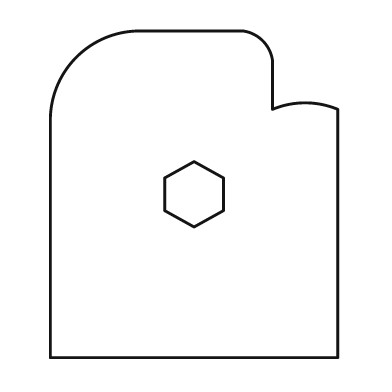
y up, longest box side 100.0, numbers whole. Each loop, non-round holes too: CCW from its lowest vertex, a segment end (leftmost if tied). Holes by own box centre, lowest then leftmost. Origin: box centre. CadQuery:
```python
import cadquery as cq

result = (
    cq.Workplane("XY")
    .moveTo(-44.0, -50.0)
    .lineTo(44.0, -50.0)
    .lineTo(44.0, 26.0)
    .threePointArc((34.0, 28.0), (24.0, 26.0))
    .lineTo(24.0, 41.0)
    .threePointArc((21.0, 47.0), (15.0, 50.0))
    .lineTo(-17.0, 50.0)
    .threePointArc((-36.0, 42.0), (-44.0, 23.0))
    .close()
    .moveTo(0.0, -10.0)
    .lineTo(9.0, -5.0)
    .lineTo(9.0, 5.0)
    .lineTo(0.0, 10.0)
    .lineTo(-9.0, 5.0)
    .lineTo(-9.0, -5.0)
    .close()
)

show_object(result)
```